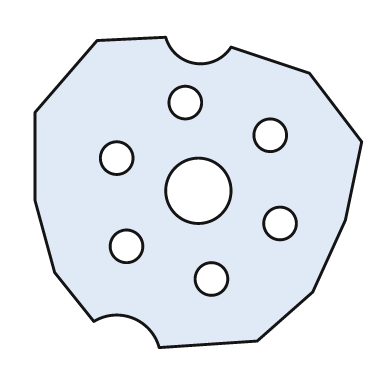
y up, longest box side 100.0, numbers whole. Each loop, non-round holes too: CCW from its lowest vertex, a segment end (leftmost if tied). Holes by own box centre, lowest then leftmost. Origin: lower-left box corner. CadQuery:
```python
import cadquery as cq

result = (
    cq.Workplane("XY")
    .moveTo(38.0, 0.0)
    .lineTo(68.0, 2.0)
    .lineTo(85.0, 17.0)
    .lineTo(95.0, 39.0)
    .lineTo(100.0, 63.0)
    .lineTo(84.0, 84.0)
    .lineTo(60.0, 92.0)
    .threePointArc((49.0, 87.0), (40.0, 95.0))
    .lineTo(19.0, 94.0)
    .lineTo(0.0, 72.0)
    .lineTo(0.0, 45.0)
    .lineTo(6.0, 23.0)
    .lineTo(18.0, 8.0)
    .threePointArc((30.0, 9.0), (38.0, 0.0))
    .close()
    .moveTo(54.0, 21.0)
    .circle(5.0)
    .moveTo(28.0, 31.0)
    .circle(5.0)
    .moveTo(75.0, 38.0)
    .circle(5.0)
    .moveTo(50.0, 48.0)
    .circle(10.0)
    .moveTo(25.0, 58.0)
    .circle(5.0)
    .moveTo(72.0, 65.0)
    .circle(5.0)
    .moveTo(46.0, 75.0)
    .circle(5.0)
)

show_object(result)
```